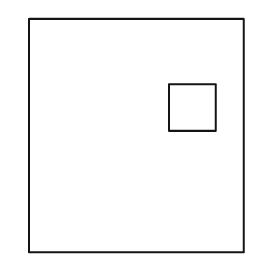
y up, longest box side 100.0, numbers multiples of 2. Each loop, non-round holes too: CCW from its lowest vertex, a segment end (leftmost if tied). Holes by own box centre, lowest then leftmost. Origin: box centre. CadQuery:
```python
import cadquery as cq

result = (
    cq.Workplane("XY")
    .moveTo(-46.0, -50.0)
    .lineTo(46.0, -50.0)
    .lineTo(46.0, 50.0)
    .lineTo(-46.0, 50.0)
    .close()
    .moveTo(14.0, 2.0)
    .lineTo(34.0, 2.0)
    .lineTo(34.0, 22.0)
    .lineTo(14.0, 22.0)
    .close()
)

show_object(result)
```